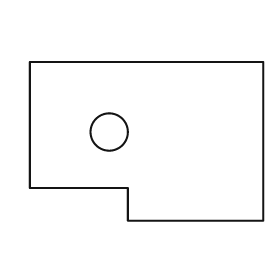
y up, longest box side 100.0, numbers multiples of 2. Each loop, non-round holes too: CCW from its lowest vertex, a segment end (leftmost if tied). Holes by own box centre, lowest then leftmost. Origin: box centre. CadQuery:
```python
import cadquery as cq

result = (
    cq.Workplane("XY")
    .moveTo(-8.0, -34.0)
    .lineTo(50.0, -34.0)
    .lineTo(50.0, 34.0)
    .lineTo(-50.0, 34.0)
    .lineTo(-50.0, -20.0)
    .lineTo(-8.0, -20.0)
    .close()
    .moveTo(-16.0, 4.0)
    .circle(8.0)
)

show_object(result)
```